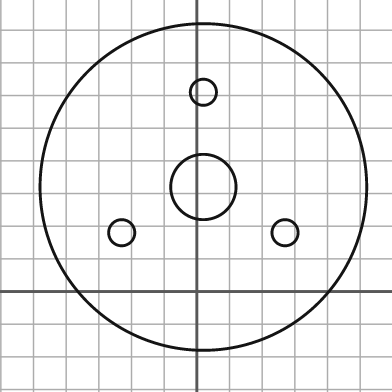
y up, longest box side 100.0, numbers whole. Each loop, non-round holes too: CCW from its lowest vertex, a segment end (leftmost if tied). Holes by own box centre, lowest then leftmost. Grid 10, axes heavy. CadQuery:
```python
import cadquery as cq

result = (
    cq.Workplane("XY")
    .moveTo(2.0, 32.0)
    .circle(50.0)
    .moveTo(-23.0, 18.0)
    .circle(4.0)
    .moveTo(27.0, 18.0)
    .circle(4.0)
    .moveTo(2.0, 32.0)
    .circle(10.0)
    .moveTo(2.0, 61.0)
    .circle(4.0)
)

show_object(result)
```